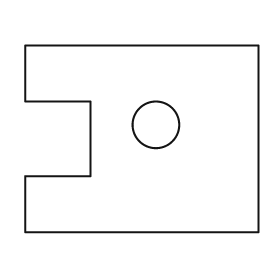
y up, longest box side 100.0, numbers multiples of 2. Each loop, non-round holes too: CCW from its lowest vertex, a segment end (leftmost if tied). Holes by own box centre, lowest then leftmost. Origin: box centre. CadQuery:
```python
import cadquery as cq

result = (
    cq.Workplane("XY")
    .moveTo(-50.0, -40.0)
    .lineTo(50.0, -40.0)
    .lineTo(50.0, 40.0)
    .lineTo(-50.0, 40.0)
    .lineTo(-50.0, 16.0)
    .lineTo(-22.0, 16.0)
    .lineTo(-22.0, -16.0)
    .lineTo(-50.0, -16.0)
    .close()
    .moveTo(6.0, 6.0)
    .circle(10.0)
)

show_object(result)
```